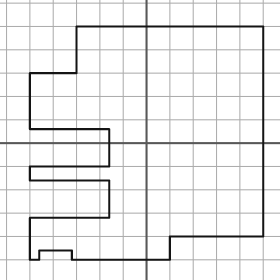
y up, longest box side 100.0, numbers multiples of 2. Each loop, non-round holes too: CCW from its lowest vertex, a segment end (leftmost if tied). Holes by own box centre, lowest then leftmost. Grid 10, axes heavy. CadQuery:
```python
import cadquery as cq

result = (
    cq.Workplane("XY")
    .moveTo(-50.0, -50.0)
    .lineTo(-46.0, -50.0)
    .lineTo(-46.0, -46.0)
    .lineTo(-32.0, -46.0)
    .lineTo(-32.0, -50.0)
    .lineTo(10.0, -50.0)
    .lineTo(10.0, -40.0)
    .lineTo(50.0, -40.0)
    .lineTo(50.0, 50.0)
    .lineTo(-30.0, 50.0)
    .lineTo(-30.0, 30.0)
    .lineTo(-50.0, 30.0)
    .lineTo(-50.0, 6.0)
    .lineTo(-16.0, 6.0)
    .lineTo(-16.0, -10.0)
    .lineTo(-50.0, -10.0)
    .lineTo(-50.0, -16.0)
    .lineTo(-16.0, -16.0)
    .lineTo(-16.0, -32.0)
    .lineTo(-50.0, -32.0)
    .close()
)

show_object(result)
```